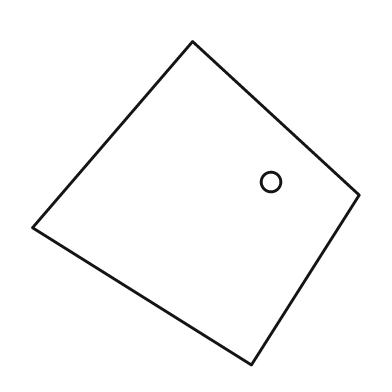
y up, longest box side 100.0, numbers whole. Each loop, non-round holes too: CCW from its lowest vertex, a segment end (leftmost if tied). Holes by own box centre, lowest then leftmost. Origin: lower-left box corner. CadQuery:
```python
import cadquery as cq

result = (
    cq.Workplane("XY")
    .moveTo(67.0, 0.0)
    .lineTo(100.0, 52.0)
    .lineTo(49.0, 99.0)
    .lineTo(0.0, 42.0)
    .close()
    .moveTo(73.0, 56.0)
    .circle(3.0)
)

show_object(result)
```